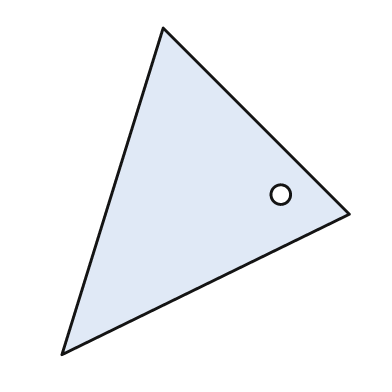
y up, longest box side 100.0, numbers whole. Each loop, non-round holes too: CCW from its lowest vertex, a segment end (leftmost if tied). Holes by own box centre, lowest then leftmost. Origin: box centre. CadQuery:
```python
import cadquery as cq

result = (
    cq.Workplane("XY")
    .moveTo(-44.0, -50.0)
    .lineTo(44.0, -7.0)
    .lineTo(-13.0, 50.0)
    .close()
    .moveTo(23.0, -1.0)
    .circle(3.0)
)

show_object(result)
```